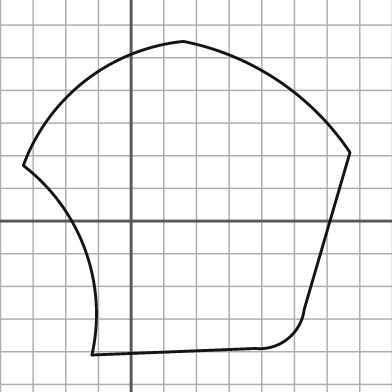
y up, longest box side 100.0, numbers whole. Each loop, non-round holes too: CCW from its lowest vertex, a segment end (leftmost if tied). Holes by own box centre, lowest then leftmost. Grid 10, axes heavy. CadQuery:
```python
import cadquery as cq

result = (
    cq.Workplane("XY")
    .moveTo(-12.0, -41.0)
    .lineTo(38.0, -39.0)
    .threePointArc((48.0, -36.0), (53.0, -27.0))
    .lineTo(67.0, 21.0)
    .threePointArc((45.0, 43.0), (16.0, 55.0))
    .threePointArc((-14.0, 43.0), (-33.0, 17.0))
    .threePointArc((-14.0, -9.0), (-12.0, -41.0))
    .close()
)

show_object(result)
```